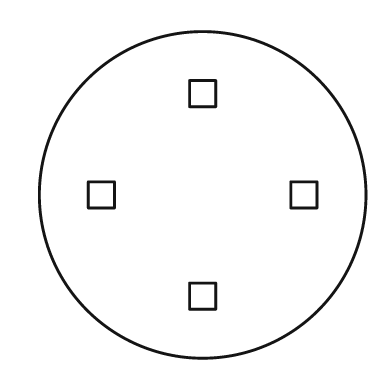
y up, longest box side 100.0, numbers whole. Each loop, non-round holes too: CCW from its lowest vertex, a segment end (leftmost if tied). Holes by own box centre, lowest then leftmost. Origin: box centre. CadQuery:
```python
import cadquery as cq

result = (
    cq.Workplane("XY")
    .moveTo(0.0, 0.0)
    .circle(50.0)
    .moveTo(-4.0, -35.0)
    .lineTo(4.0, -35.0)
    .lineTo(4.0, -27.0)
    .lineTo(-4.0, -27.0)
    .close()
    .moveTo(-35.0, -4.0)
    .lineTo(-27.0, -4.0)
    .lineTo(-27.0, 4.0)
    .lineTo(-35.0, 4.0)
    .close()
    .moveTo(27.0, -4.0)
    .lineTo(35.0, -4.0)
    .lineTo(35.0, 4.0)
    .lineTo(27.0, 4.0)
    .close()
    .moveTo(-4.0, 27.0)
    .lineTo(4.0, 27.0)
    .lineTo(4.0, 35.0)
    .lineTo(-4.0, 35.0)
    .close()
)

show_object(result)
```